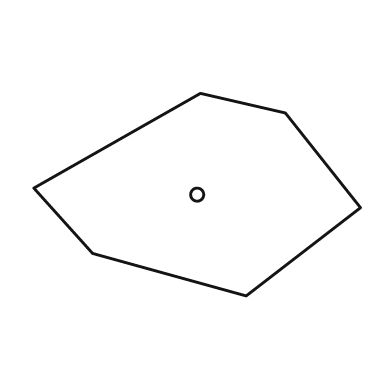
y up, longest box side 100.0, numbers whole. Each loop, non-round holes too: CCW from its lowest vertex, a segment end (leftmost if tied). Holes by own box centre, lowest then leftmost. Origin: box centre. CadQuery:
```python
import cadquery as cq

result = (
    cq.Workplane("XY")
    .moveTo(15.0, -31.0)
    .lineTo(50.0, -4.0)
    .lineTo(27.0, 25.0)
    .lineTo(1.0, 31.0)
    .lineTo(-50.0, 2.0)
    .lineTo(-32.0, -18.0)
    .close()
    .moveTo(0.0, 0.0)
    .circle(2.0)
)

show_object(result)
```